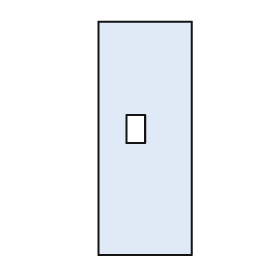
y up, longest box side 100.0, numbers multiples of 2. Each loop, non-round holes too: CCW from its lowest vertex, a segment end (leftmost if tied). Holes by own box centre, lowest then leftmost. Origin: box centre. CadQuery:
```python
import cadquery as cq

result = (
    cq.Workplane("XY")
    .moveTo(-20.0, -50.0)
    .lineTo(20.0, -50.0)
    .lineTo(20.0, 50.0)
    .lineTo(-20.0, 50.0)
    .close()
    .moveTo(-8.0, -2.0)
    .lineTo(0.0, -2.0)
    .lineTo(0.0, 10.0)
    .lineTo(-8.0, 10.0)
    .close()
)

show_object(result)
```